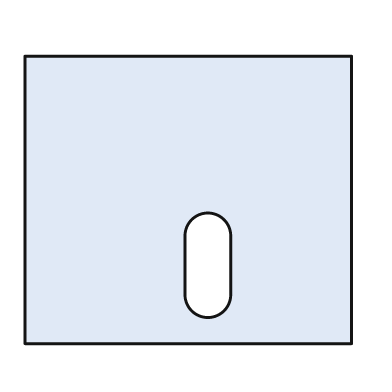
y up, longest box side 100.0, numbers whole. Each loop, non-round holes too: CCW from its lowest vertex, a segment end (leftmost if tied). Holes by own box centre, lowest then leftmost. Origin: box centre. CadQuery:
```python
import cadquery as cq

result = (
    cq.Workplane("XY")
    .moveTo(-50.0, -44.0)
    .lineTo(50.0, -44.0)
    .lineTo(50.0, 44.0)
    .lineTo(-50.0, 44.0)
    .close()
    .moveTo(-1.0, -29.0)
    .threePointArc((6.0, -36.0), (13.0, -29.0))
    .lineTo(13.0, -11.0)
    .threePointArc((6.0, -4.0), (-1.0, -11.0))
    .close()
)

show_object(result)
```